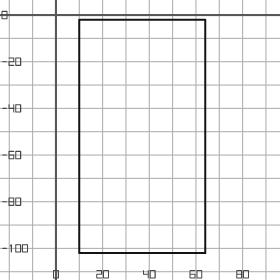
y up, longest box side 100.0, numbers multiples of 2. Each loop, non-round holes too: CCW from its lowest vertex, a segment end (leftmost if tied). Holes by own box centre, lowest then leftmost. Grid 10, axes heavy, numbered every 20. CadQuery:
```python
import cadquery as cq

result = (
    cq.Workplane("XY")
    .moveTo(10.0, -102.0)
    .lineTo(64.0, -102.0)
    .lineTo(64.0, -2.0)
    .lineTo(10.0, -2.0)
    .close()
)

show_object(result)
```